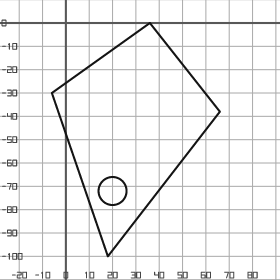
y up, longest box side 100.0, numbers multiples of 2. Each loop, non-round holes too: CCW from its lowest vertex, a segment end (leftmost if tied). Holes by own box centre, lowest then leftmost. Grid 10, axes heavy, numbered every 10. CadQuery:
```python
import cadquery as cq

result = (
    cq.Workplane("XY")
    .moveTo(18.0, -100.0)
    .lineTo(66.0, -38.0)
    .lineTo(36.0, 0.0)
    .lineTo(-6.0, -30.0)
    .close()
    .moveTo(20.0, -72.0)
    .circle(6.0)
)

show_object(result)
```